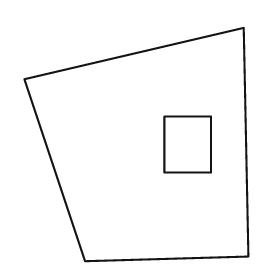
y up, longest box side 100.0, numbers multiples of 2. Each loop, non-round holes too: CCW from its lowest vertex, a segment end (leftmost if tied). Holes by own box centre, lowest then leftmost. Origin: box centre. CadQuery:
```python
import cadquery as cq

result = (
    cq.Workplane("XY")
    .moveTo(-22.0, -50.0)
    .lineTo(48.0, -48.0)
    .lineTo(46.0, 50.0)
    .lineTo(-48.0, 28.0)
    .close()
    .moveTo(12.0, -12.0)
    .lineTo(32.0, -12.0)
    .lineTo(32.0, 12.0)
    .lineTo(12.0, 12.0)
    .close()
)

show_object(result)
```